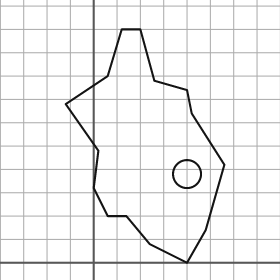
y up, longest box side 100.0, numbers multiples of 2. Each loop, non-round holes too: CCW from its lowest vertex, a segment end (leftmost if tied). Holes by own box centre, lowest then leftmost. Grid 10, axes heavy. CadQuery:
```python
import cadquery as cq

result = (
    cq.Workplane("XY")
    .moveTo(40.0, 0.0)
    .lineTo(48.0, 14.0)
    .lineTo(56.0, 42.0)
    .lineTo(42.0, 64.0)
    .lineTo(40.0, 74.0)
    .lineTo(26.0, 78.0)
    .lineTo(20.0, 100.0)
    .lineTo(12.0, 100.0)
    .lineTo(6.0, 80.0)
    .lineTo(-12.0, 68.0)
    .lineTo(2.0, 48.0)
    .lineTo(0.0, 32.0)
    .lineTo(6.0, 20.0)
    .lineTo(14.0, 20.0)
    .lineTo(24.0, 8.0)
    .close()
    .moveTo(40.0, 38.0)
    .circle(6.0)
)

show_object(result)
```